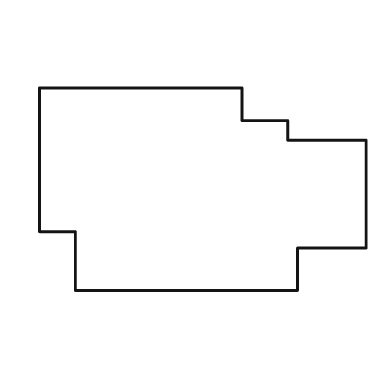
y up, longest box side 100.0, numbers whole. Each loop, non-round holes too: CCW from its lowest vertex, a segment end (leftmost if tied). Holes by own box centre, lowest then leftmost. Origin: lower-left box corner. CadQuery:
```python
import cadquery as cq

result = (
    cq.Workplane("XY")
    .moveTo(11.0, 0.0)
    .lineTo(79.0, 0.0)
    .lineTo(79.0, 13.0)
    .lineTo(100.0, 13.0)
    .lineTo(100.0, 46.0)
    .lineTo(76.0, 46.0)
    .lineTo(76.0, 52.0)
    .lineTo(62.0, 52.0)
    .lineTo(62.0, 62.0)
    .lineTo(0.0, 62.0)
    .lineTo(0.0, 18.0)
    .lineTo(11.0, 18.0)
    .close()
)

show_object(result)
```